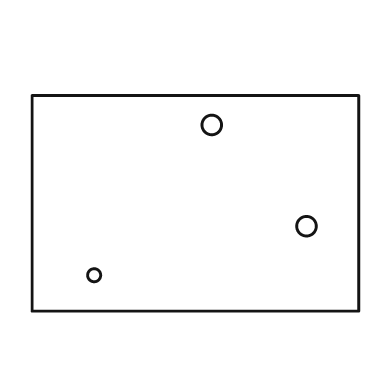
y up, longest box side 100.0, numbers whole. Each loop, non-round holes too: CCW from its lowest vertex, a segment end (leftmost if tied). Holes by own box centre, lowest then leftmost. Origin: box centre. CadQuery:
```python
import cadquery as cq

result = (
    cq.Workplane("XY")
    .moveTo(-50.0, -33.0)
    .lineTo(50.0, -33.0)
    .lineTo(50.0, 33.0)
    .lineTo(-50.0, 33.0)
    .close()
    .moveTo(-31.0, -22.0)
    .circle(2.0)
    .moveTo(34.0, -7.0)
    .circle(3.0)
    .moveTo(5.0, 24.0)
    .circle(3.0)
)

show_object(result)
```